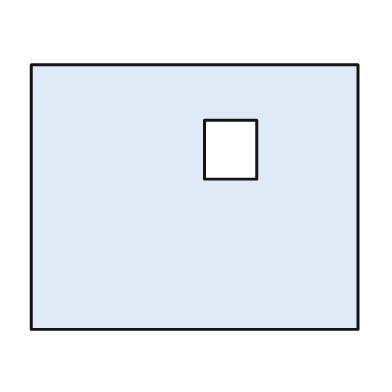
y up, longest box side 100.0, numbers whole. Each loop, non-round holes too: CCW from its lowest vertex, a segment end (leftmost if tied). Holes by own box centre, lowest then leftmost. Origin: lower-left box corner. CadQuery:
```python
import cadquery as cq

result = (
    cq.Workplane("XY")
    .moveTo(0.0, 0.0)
    .lineTo(100.0, 0.0)
    .lineTo(100.0, 81.0)
    .lineTo(0.0, 81.0)
    .close()
    .moveTo(53.0, 46.0)
    .lineTo(69.0, 46.0)
    .lineTo(69.0, 64.0)
    .lineTo(53.0, 64.0)
    .close()
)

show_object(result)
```